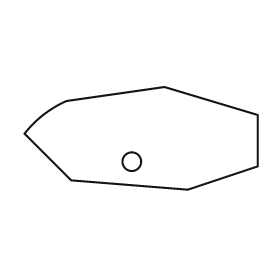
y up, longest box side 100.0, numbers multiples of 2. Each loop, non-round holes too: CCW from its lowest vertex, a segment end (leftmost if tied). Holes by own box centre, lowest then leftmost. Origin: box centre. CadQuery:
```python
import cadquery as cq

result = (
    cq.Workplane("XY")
    .moveTo(20.0, -22.0)
    .lineTo(50.0, -12.0)
    .lineTo(50.0, 10.0)
    .lineTo(10.0, 22.0)
    .lineTo(-32.0, 16.0)
    .threePointArc((-42.0, 10.0), (-50.0, 2.0))
    .lineTo(-30.0, -18.0)
    .close()
    .moveTo(-4.0, -10.0)
    .circle(4.0)
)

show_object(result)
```